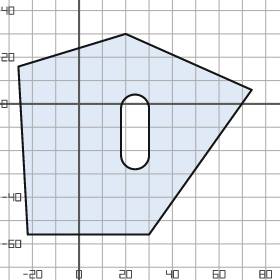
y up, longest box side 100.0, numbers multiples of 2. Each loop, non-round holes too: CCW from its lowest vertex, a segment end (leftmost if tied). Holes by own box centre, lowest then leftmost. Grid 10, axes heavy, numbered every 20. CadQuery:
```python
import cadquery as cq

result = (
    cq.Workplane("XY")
    .moveTo(-22.0, -56.0)
    .lineTo(30.0, -56.0)
    .lineTo(74.0, 6.0)
    .lineTo(20.0, 30.0)
    .lineTo(-26.0, 16.0)
    .close()
    .moveTo(18.0, -22.0)
    .threePointArc((24.0, -28.0), (30.0, -22.0))
    .lineTo(30.0, -2.0)
    .threePointArc((24.0, 4.0), (18.0, -2.0))
    .close()
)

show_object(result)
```